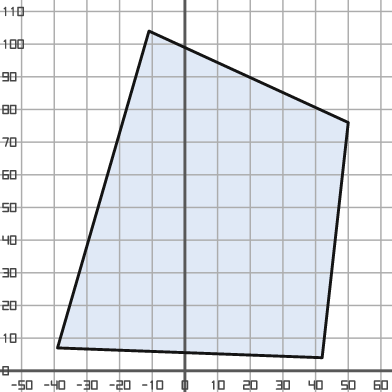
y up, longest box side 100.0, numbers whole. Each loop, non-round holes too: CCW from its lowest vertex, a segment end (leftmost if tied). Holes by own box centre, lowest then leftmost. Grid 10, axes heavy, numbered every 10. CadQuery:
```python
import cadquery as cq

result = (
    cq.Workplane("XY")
    .moveTo(42.0, 4.0)
    .lineTo(50.0, 76.0)
    .lineTo(-11.0, 104.0)
    .lineTo(-39.0, 7.0)
    .close()
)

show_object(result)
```